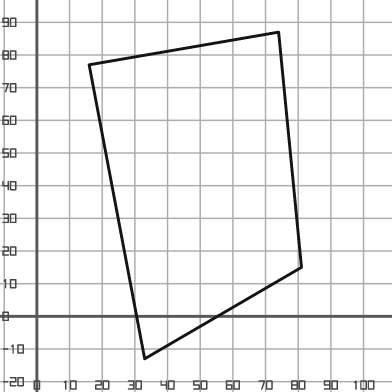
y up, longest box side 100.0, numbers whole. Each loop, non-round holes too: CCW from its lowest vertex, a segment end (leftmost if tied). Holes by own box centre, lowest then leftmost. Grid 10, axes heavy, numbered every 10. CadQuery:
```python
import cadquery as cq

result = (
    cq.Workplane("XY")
    .moveTo(33.0, -13.0)
    .lineTo(81.0, 15.0)
    .lineTo(74.0, 87.0)
    .lineTo(16.0, 77.0)
    .close()
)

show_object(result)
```